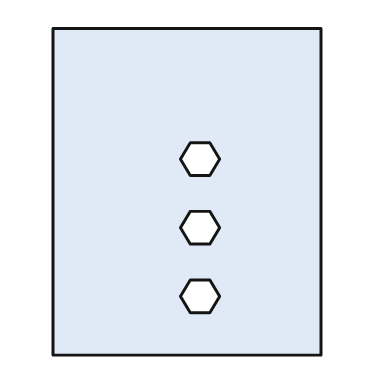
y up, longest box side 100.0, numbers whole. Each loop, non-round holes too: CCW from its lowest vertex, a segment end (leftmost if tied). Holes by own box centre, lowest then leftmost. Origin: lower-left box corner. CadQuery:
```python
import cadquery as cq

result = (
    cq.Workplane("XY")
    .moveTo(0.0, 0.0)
    .lineTo(82.0, 0.0)
    .lineTo(82.0, 100.0)
    .lineTo(0.0, 100.0)
    .close()
    .moveTo(42.0, 13.0)
    .lineTo(48.0, 13.0)
    .lineTo(51.0, 18.0)
    .lineTo(48.0, 23.0)
    .lineTo(42.0, 23.0)
    .lineTo(39.0, 18.0)
    .close()
    .moveTo(42.0, 34.0)
    .lineTo(48.0, 34.0)
    .lineTo(51.0, 39.0)
    .lineTo(48.0, 44.0)
    .lineTo(42.0, 44.0)
    .lineTo(39.0, 39.0)
    .close()
    .moveTo(42.0, 55.0)
    .lineTo(48.0, 55.0)
    .lineTo(51.0, 60.0)
    .lineTo(48.0, 65.0)
    .lineTo(42.0, 65.0)
    .lineTo(39.0, 60.0)
    .close()
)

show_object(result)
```